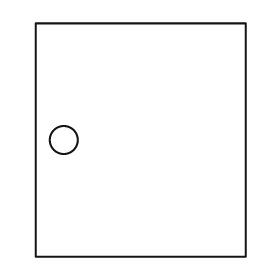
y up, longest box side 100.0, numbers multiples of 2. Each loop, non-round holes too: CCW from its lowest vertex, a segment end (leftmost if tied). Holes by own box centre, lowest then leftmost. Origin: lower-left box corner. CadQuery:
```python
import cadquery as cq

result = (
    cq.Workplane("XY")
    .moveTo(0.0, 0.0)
    .lineTo(90.0, 0.0)
    .lineTo(90.0, 100.0)
    .lineTo(0.0, 100.0)
    .close()
    .moveTo(12.0, 50.0)
    .circle(6.0)
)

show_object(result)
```